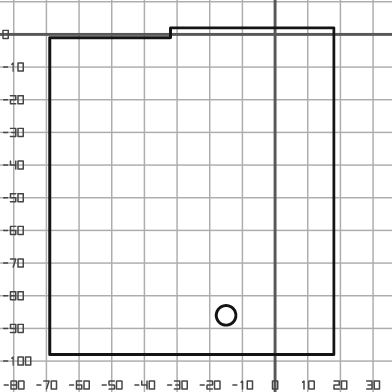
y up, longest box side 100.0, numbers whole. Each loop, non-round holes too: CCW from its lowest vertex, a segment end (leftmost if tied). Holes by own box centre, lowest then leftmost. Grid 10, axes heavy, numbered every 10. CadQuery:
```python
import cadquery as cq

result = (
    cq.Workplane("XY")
    .moveTo(-69.0, -98.0)
    .lineTo(18.0, -98.0)
    .lineTo(18.0, 2.0)
    .lineTo(-32.0, 2.0)
    .lineTo(-32.0, -1.0)
    .lineTo(-69.0, -1.0)
    .close()
    .moveTo(-15.0, -86.0)
    .circle(3.0)
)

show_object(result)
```